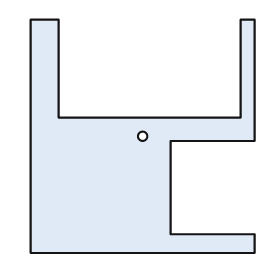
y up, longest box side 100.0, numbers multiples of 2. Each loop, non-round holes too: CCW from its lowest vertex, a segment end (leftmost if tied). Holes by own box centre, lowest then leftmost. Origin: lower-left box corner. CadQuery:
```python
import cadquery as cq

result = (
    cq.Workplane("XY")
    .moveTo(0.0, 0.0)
    .lineTo(96.0, 0.0)
    .lineTo(96.0, 8.0)
    .lineTo(60.0, 8.0)
    .lineTo(60.0, 48.0)
    .lineTo(96.0, 48.0)
    .lineTo(96.0, 100.0)
    .lineTo(90.0, 100.0)
    .lineTo(90.0, 58.0)
    .lineTo(12.0, 58.0)
    .lineTo(12.0, 100.0)
    .lineTo(0.0, 100.0)
    .close()
    .moveTo(48.0, 50.0)
    .circle(2.0)
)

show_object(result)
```